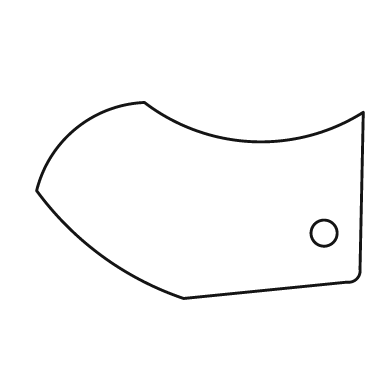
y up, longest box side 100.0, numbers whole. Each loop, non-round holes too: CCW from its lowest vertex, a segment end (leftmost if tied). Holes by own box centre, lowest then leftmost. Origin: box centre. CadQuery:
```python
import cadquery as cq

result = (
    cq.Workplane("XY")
    .moveTo(-5.0, -30.0)
    .lineTo(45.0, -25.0)
    .threePointArc((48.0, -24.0), (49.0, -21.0))
    .lineTo(50.0, 27.0)
    .threePointArc((16.0, 18.0), (-17.0, 30.0))
    .threePointArc((-38.0, 22.0), (-50.0, 3.0))
    .threePointArc((-30.0, -17.0), (-5.0, -30.0))
    .close()
    .moveTo(38.0, -10.0)
    .circle(4.0)
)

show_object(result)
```